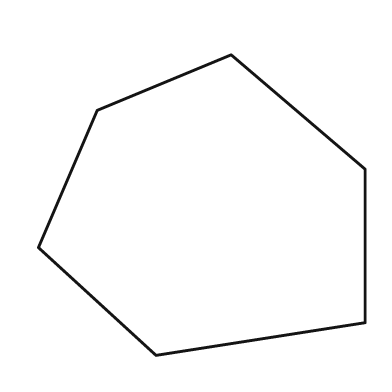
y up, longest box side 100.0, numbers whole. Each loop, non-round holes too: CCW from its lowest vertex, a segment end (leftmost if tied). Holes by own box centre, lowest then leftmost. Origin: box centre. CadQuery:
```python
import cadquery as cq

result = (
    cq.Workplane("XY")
    .moveTo(-14.0, -46.0)
    .lineTo(50.0, -36.0)
    .lineTo(50.0, 11.0)
    .lineTo(9.0, 46.0)
    .lineTo(-32.0, 29.0)
    .lineTo(-50.0, -13.0)
    .close()
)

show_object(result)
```